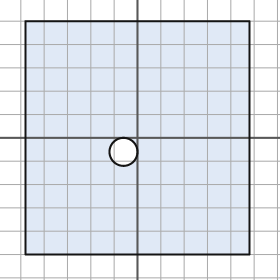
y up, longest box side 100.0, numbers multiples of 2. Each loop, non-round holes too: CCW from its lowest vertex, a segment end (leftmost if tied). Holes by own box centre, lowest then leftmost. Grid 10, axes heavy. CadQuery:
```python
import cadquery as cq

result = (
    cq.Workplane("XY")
    .moveTo(-48.0, -50.0)
    .lineTo(48.0, -50.0)
    .lineTo(48.0, 50.0)
    .lineTo(-48.0, 50.0)
    .close()
    .moveTo(-6.0, -6.0)
    .circle(6.0)
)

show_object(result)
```